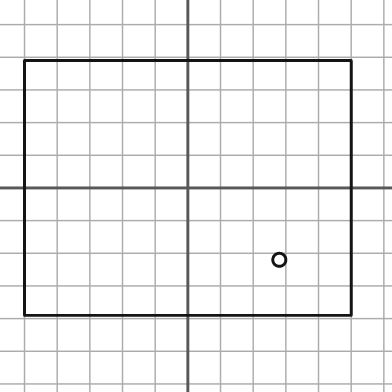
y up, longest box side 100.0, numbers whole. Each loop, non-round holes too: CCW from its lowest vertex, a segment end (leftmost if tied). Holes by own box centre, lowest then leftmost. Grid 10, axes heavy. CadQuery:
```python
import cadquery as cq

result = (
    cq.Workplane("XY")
    .moveTo(-50.0, -39.0)
    .lineTo(50.0, -39.0)
    .lineTo(50.0, 39.0)
    .lineTo(-50.0, 39.0)
    .close()
    .moveTo(28.0, -22.0)
    .circle(2.0)
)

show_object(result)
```